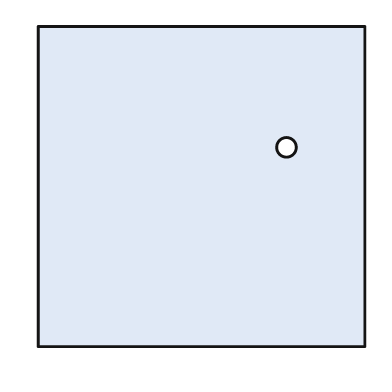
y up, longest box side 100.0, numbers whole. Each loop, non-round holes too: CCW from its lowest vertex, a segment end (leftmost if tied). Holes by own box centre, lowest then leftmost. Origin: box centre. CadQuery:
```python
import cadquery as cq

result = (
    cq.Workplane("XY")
    .moveTo(-50.0, -49.0)
    .lineTo(50.0, -49.0)
    .lineTo(50.0, 49.0)
    .lineTo(-50.0, 49.0)
    .close()
    .moveTo(26.0, 12.0)
    .circle(3.0)
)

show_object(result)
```